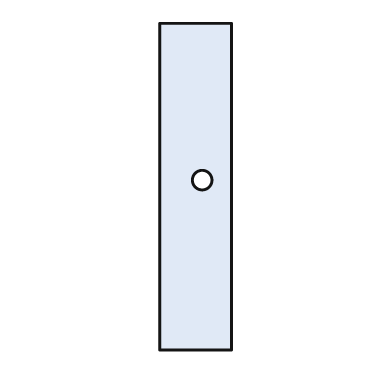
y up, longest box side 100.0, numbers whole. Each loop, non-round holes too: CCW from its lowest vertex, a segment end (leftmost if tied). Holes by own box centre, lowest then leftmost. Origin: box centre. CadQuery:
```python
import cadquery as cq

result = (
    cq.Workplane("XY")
    .moveTo(-11.0, -50.0)
    .lineTo(11.0, -50.0)
    .lineTo(11.0, 50.0)
    .lineTo(-11.0, 50.0)
    .close()
    .moveTo(2.0, 2.0)
    .circle(3.0)
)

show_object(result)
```